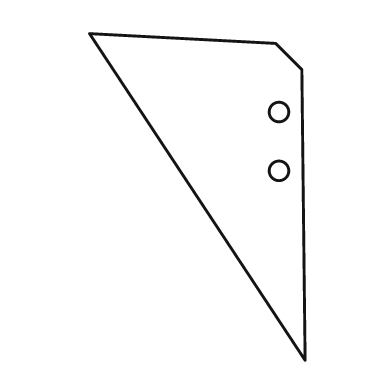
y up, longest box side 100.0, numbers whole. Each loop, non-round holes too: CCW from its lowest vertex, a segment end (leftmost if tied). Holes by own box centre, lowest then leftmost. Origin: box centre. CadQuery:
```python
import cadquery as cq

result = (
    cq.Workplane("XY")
    .moveTo(33.0, -50.0)
    .lineTo(32.0, 39.0)
    .lineTo(24.0, 47.0)
    .lineTo(-33.0, 50.0)
    .close()
    .moveTo(25.0, 8.0)
    .circle(3.0)
    .moveTo(25.0, 26.0)
    .circle(3.0)
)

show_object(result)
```